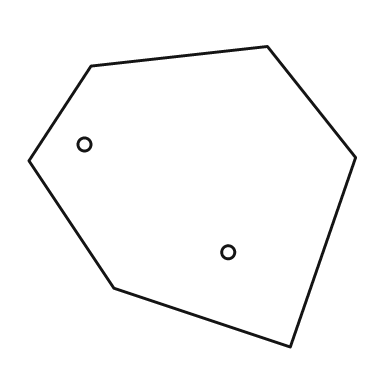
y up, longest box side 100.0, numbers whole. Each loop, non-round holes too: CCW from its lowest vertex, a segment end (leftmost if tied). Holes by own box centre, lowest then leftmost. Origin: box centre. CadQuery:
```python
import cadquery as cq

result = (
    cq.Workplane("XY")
    .moveTo(30.0, -46.0)
    .lineTo(50.0, 12.0)
    .lineTo(23.0, 46.0)
    .lineTo(-31.0, 40.0)
    .lineTo(-50.0, 11.0)
    .lineTo(-24.0, -28.0)
    .close()
    .moveTo(11.0, -17.0)
    .circle(2.0)
    .moveTo(-33.0, 16.0)
    .circle(2.0)
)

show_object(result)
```